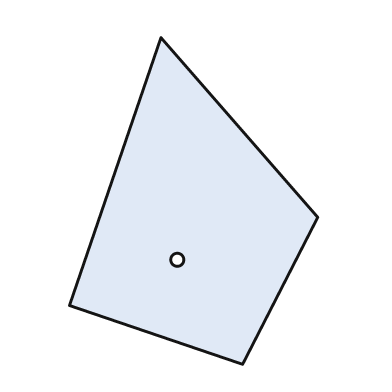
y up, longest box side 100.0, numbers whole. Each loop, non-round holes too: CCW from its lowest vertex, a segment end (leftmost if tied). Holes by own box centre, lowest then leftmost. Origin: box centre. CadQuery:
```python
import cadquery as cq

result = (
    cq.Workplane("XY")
    .moveTo(15.0, -50.0)
    .lineTo(38.0, -5.0)
    .lineTo(-10.0, 50.0)
    .lineTo(-38.0, -32.0)
    .close()
    .moveTo(-5.0, -18.0)
    .circle(2.0)
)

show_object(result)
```